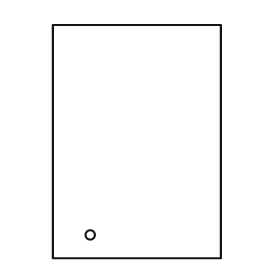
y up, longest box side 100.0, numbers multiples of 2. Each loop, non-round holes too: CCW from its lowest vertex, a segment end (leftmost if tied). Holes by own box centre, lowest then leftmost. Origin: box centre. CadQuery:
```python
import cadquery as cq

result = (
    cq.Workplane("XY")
    .moveTo(-36.0, -50.0)
    .lineTo(36.0, -50.0)
    .lineTo(36.0, 50.0)
    .lineTo(-36.0, 50.0)
    .close()
    .moveTo(-20.0, -40.0)
    .circle(2.0)
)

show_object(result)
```